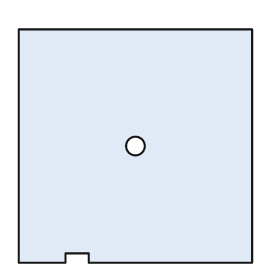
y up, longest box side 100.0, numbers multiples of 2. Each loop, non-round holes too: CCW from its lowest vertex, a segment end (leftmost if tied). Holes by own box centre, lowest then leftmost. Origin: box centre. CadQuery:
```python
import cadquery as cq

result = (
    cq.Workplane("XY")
    .moveTo(-50.0, -50.0)
    .lineTo(-30.0, -50.0)
    .lineTo(-30.0, -46.0)
    .lineTo(-20.0, -46.0)
    .lineTo(-20.0, -50.0)
    .lineTo(50.0, -50.0)
    .lineTo(50.0, 50.0)
    .lineTo(-50.0, 50.0)
    .close()
    .moveTo(0.0, 0.0)
    .circle(4.0)
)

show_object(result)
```